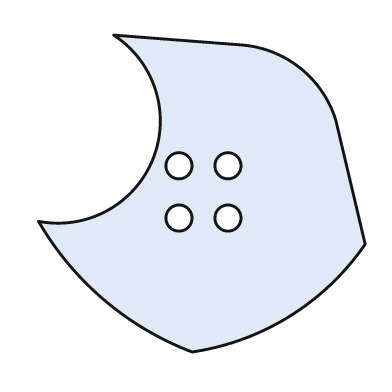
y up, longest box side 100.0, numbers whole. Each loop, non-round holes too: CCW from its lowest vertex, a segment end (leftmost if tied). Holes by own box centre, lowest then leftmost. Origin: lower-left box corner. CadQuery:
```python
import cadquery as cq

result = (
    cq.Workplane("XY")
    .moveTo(47.0, 0.0)
    .threePointArc((77.0, 11.0), (100.0, 33.0))
    .lineTo(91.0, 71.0)
    .threePointArc((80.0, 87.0), (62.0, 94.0))
    .lineTo(23.0, 97.0)
    .threePointArc((35.0, 59.0), (0.0, 40.0))
    .threePointArc((20.0, 16.0), (47.0, 0.0))
    .close()
    .moveTo(43.0, 41.0)
    .circle(4.0)
    .moveTo(58.0, 41.0)
    .circle(4.0)
    .moveTo(43.0, 57.0)
    .circle(4.0)
    .moveTo(58.0, 57.0)
    .circle(4.0)
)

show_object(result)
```